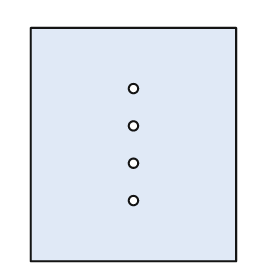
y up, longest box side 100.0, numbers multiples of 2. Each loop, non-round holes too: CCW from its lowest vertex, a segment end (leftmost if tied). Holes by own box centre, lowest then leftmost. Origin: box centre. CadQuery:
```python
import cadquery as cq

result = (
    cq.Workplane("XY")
    .moveTo(-44.0, -50.0)
    .lineTo(44.0, -50.0)
    .lineTo(44.0, 50.0)
    .lineTo(-44.0, 50.0)
    .close()
    .moveTo(0.0, -24.0)
    .circle(2.0)
    .moveTo(0.0, -8.0)
    .circle(2.0)
    .moveTo(0.0, 8.0)
    .circle(2.0)
    .moveTo(0.0, 24.0)
    .circle(2.0)
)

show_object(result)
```